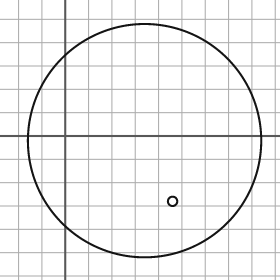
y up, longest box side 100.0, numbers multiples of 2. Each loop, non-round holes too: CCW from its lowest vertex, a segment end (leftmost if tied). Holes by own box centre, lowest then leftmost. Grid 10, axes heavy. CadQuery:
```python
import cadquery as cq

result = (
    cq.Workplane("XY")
    .moveTo(34.0, -2.0)
    .circle(50.0)
    .moveTo(46.0, -28.0)
    .circle(2.0)
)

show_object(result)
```